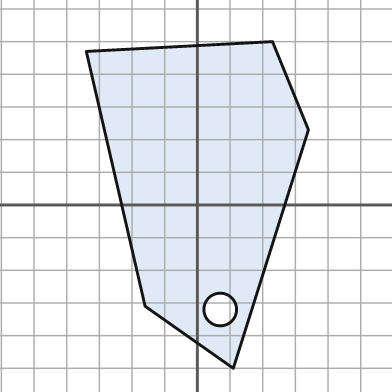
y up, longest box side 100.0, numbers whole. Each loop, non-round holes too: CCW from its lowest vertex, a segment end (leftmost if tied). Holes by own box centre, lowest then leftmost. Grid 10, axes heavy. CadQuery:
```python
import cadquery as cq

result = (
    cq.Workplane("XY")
    .moveTo(11.0, -50.0)
    .lineTo(34.0, 23.0)
    .lineTo(23.0, 50.0)
    .lineTo(-34.0, 47.0)
    .lineTo(-16.0, -31.0)
    .close()
    .moveTo(7.0, -32.0)
    .circle(5.0)
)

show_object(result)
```